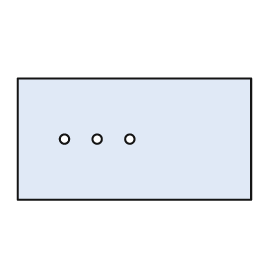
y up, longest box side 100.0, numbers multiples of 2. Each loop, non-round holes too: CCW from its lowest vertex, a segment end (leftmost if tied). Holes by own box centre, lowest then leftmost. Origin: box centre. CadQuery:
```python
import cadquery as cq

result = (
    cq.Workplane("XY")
    .moveTo(-50.0, -26.0)
    .lineTo(50.0, -26.0)
    .lineTo(50.0, 26.0)
    .lineTo(-50.0, 26.0)
    .close()
    .moveTo(-30.0, 0.0)
    .circle(2.0)
    .moveTo(-16.0, 0.0)
    .circle(2.0)
    .moveTo(-2.0, 0.0)
    .circle(2.0)
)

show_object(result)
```